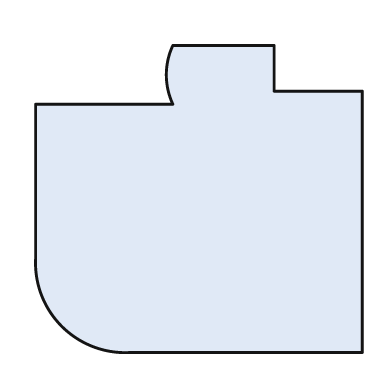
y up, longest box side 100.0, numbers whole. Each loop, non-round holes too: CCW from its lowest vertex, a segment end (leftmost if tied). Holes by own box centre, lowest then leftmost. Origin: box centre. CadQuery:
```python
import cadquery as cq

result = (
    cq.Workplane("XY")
    .moveTo(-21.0, -47.0)
    .lineTo(50.0, -47.0)
    .lineTo(50.0, 33.0)
    .lineTo(23.0, 33.0)
    .lineTo(23.0, 47.0)
    .lineTo(-8.0, 47.0)
    .threePointArc((-10.0, 38.0), (-8.0, 29.0))
    .lineTo(-50.0, 29.0)
    .lineTo(-50.0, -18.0)
    .threePointArc((-42.0, -39.0), (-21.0, -47.0))
    .close()
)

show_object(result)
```